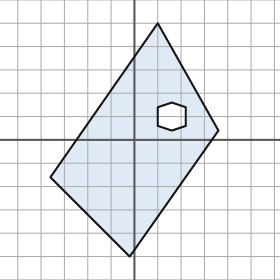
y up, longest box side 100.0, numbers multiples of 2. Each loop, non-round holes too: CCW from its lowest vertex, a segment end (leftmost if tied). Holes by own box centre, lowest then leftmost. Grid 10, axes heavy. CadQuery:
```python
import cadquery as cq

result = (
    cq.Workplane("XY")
    .moveTo(-2.0, -50.0)
    .lineTo(36.0, 4.0)
    .lineTo(10.0, 50.0)
    .lineTo(-36.0, -16.0)
    .close()
    .moveTo(16.0, 4.0)
    .lineTo(22.0, 6.0)
    .lineTo(22.0, 14.0)
    .lineTo(16.0, 16.0)
    .lineTo(10.0, 14.0)
    .lineTo(10.0, 6.0)
    .close()
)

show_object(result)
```